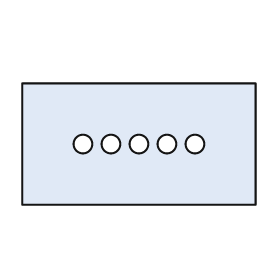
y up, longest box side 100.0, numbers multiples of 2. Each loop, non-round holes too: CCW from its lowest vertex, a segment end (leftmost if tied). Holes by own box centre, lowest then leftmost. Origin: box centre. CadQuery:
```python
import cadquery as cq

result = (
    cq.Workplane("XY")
    .moveTo(-50.0, -26.0)
    .lineTo(50.0, -26.0)
    .lineTo(50.0, 26.0)
    .lineTo(-50.0, 26.0)
    .close()
    .moveTo(-24.0, 0.0)
    .circle(4.0)
    .moveTo(-12.0, 0.0)
    .circle(4.0)
    .moveTo(0.0, 0.0)
    .circle(4.0)
    .moveTo(12.0, 0.0)
    .circle(4.0)
    .moveTo(24.0, 0.0)
    .circle(4.0)
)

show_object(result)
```